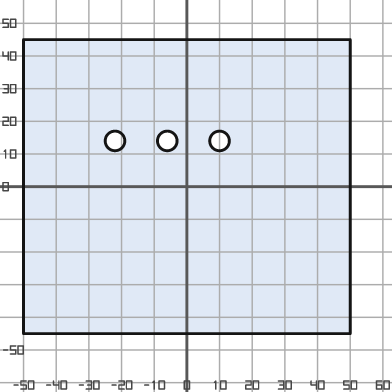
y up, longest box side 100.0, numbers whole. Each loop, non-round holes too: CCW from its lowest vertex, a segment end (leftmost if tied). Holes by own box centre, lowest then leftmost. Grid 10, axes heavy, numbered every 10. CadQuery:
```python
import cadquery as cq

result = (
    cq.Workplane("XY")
    .moveTo(-50.0, -45.0)
    .lineTo(50.0, -45.0)
    .lineTo(50.0, 45.0)
    .lineTo(-50.0, 45.0)
    .close()
    .moveTo(-22.0, 14.0)
    .circle(3.0)
    .moveTo(-6.0, 14.0)
    .circle(3.0)
    .moveTo(10.0, 14.0)
    .circle(3.0)
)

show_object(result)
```